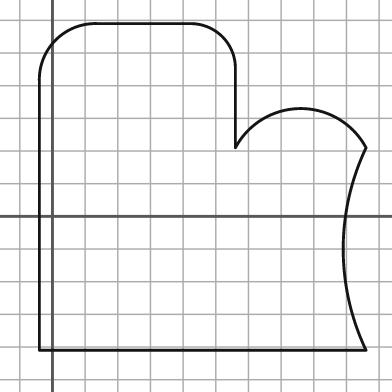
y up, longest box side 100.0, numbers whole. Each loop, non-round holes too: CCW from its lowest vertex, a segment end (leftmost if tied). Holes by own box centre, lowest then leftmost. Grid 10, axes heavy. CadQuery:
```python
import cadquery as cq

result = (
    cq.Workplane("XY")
    .moveTo(-4.0, -41.0)
    .lineTo(96.0, -41.0)
    .threePointArc((89.0, -10.0), (96.0, 21.0))
    .threePointArc((76.0, 33.0), (56.0, 21.0))
    .lineTo(56.0, 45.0)
    .threePointArc((52.0, 55.0), (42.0, 59.0))
    .lineTo(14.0, 59.0)
    .threePointArc((1.0, 54.0), (-4.0, 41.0))
    .close()
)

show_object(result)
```